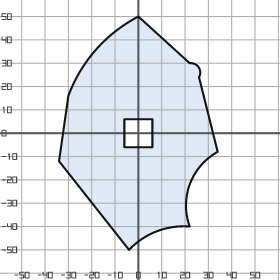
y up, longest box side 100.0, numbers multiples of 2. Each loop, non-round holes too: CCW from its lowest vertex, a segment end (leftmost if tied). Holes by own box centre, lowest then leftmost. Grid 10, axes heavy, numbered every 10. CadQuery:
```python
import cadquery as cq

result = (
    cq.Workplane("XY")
    .moveTo(-4.0, -50.0)
    .threePointArc((8.0, -42.0), (22.0, -40.0))
    .threePointArc((22.0, -22.0), (34.0, -8.0))
    .lineTo(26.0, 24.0)
    .threePointArc((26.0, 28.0), (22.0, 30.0))
    .lineTo(0.0, 50.0)
    .threePointArc((-18.0, 36.0), (-30.0, 16.0))
    .lineTo(-34.0, -12.0)
    .close()
    .moveTo(-6.0, -6.0)
    .lineTo(6.0, -6.0)
    .lineTo(6.0, 6.0)
    .lineTo(-6.0, 6.0)
    .close()
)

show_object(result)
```